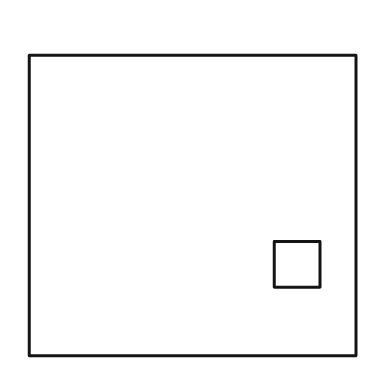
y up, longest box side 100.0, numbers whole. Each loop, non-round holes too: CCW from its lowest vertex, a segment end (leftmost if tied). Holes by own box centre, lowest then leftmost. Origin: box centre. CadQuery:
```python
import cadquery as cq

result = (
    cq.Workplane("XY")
    .moveTo(-50.0, -46.0)
    .lineTo(50.0, -46.0)
    .lineTo(50.0, 46.0)
    .lineTo(-50.0, 46.0)
    .close()
    .moveTo(25.0, -25.0)
    .lineTo(39.0, -25.0)
    .lineTo(39.0, -11.0)
    .lineTo(25.0, -11.0)
    .close()
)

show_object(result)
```